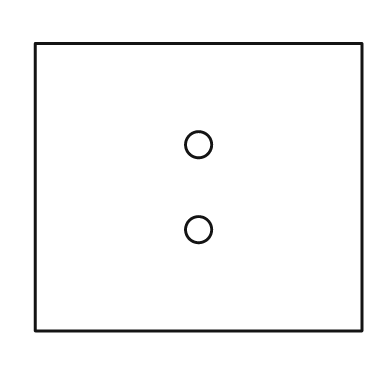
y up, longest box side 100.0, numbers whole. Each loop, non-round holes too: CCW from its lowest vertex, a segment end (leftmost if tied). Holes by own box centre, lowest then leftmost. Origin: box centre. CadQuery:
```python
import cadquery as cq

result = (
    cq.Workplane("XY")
    .moveTo(-50.0, -44.0)
    .lineTo(50.0, -44.0)
    .lineTo(50.0, 44.0)
    .lineTo(-50.0, 44.0)
    .close()
    .moveTo(0.0, -13.0)
    .circle(4.0)
    .moveTo(0.0, 13.0)
    .circle(4.0)
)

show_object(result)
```